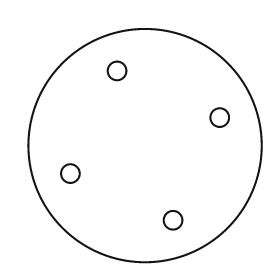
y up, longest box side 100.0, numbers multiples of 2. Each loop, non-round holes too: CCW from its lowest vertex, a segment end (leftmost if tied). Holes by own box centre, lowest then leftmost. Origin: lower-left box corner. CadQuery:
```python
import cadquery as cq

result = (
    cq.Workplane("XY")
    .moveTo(50.0, 50.0)
    .circle(50.0)
    .moveTo(62.0, 18.0)
    .circle(4.0)
    .moveTo(18.0, 38.0)
    .circle(4.0)
    .moveTo(82.0, 62.0)
    .circle(4.0)
    .moveTo(38.0, 82.0)
    .circle(4.0)
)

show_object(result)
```